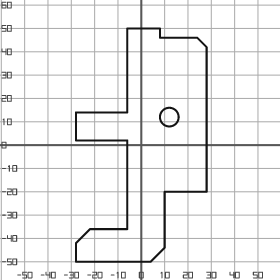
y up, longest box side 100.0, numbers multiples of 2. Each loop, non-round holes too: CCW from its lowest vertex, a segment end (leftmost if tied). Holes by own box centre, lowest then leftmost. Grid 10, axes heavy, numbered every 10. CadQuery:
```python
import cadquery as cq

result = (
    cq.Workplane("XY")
    .moveTo(-28.0, -50.0)
    .lineTo(4.0, -50.0)
    .lineTo(10.0, -44.0)
    .lineTo(10.0, -20.0)
    .lineTo(28.0, -20.0)
    .lineTo(28.0, 42.0)
    .lineTo(24.0, 46.0)
    .lineTo(8.0, 46.0)
    .lineTo(8.0, 50.0)
    .lineTo(-6.0, 50.0)
    .lineTo(-6.0, 14.0)
    .lineTo(-28.0, 14.0)
    .lineTo(-28.0, 2.0)
    .lineTo(-6.0, 2.0)
    .lineTo(-6.0, -36.0)
    .lineTo(-22.0, -36.0)
    .lineTo(-28.0, -42.0)
    .close()
    .moveTo(12.0, 12.0)
    .circle(4.0)
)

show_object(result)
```